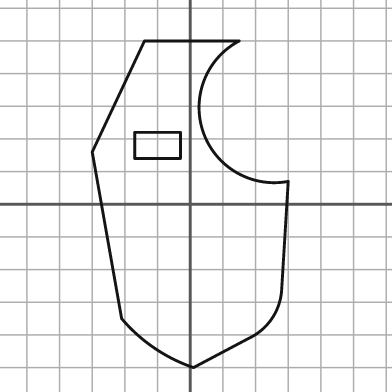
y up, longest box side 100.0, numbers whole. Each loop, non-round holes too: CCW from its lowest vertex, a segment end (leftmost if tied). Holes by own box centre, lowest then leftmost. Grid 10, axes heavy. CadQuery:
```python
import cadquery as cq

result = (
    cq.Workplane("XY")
    .moveTo(1.0, -50.0)
    .lineTo(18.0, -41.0)
    .threePointArc((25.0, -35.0), (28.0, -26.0))
    .lineTo(30.0, 7.0)
    .threePointArc((4.0, 22.0), (15.0, 50.0))
    .lineTo(-14.0, 50.0)
    .lineTo(-30.0, 16.0)
    .lineTo(-21.0, -35.0)
    .threePointArc((-11.0, -44.0), (1.0, -50.0))
    .close()
    .moveTo(-17.0, 14.0)
    .lineTo(-3.0, 14.0)
    .lineTo(-3.0, 22.0)
    .lineTo(-17.0, 22.0)
    .close()
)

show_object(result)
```